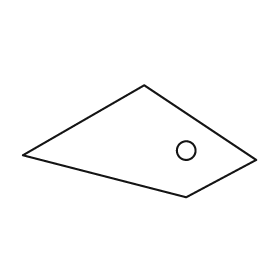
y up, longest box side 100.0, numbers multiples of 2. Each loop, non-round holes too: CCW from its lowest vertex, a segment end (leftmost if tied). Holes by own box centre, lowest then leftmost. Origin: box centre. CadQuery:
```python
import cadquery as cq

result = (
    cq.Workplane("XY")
    .moveTo(20.0, -24.0)
    .lineTo(50.0, -8.0)
    .lineTo(2.0, 24.0)
    .lineTo(-50.0, -6.0)
    .close()
    .moveTo(20.0, -4.0)
    .circle(4.0)
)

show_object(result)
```